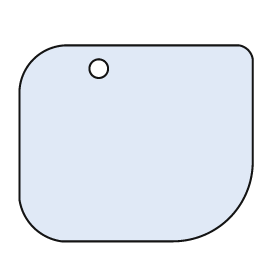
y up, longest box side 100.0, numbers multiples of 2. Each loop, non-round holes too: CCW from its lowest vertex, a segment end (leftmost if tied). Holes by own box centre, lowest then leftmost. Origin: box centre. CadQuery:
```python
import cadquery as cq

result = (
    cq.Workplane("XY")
    .moveTo(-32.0, -42.0)
    .lineTo(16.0, -42.0)
    .threePointArc((40.0, -32.0), (50.0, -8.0))
    .lineTo(50.0, 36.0)
    .threePointArc((48.0, 40.0), (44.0, 42.0))
    .lineTo(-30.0, 42.0)
    .threePointArc((-44.0, 36.0), (-50.0, 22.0))
    .lineTo(-50.0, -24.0)
    .threePointArc((-44.0, -36.0), (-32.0, -42.0))
    .close()
    .moveTo(-16.0, 32.0)
    .circle(4.0)
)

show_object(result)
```